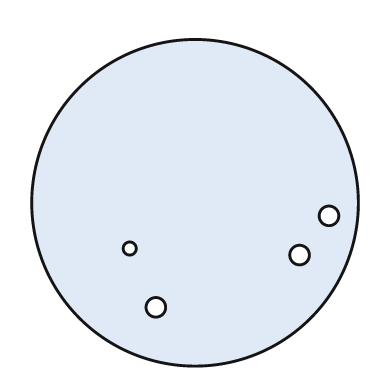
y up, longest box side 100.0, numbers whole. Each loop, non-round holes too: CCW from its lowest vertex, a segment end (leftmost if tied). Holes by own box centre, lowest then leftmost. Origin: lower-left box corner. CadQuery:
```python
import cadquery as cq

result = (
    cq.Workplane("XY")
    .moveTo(50.0, 50.0)
    .circle(50.0)
    .moveTo(38.0, 18.0)
    .circle(3.0)
    .moveTo(82.0, 34.0)
    .circle(3.0)
    .moveTo(30.0, 36.0)
    .circle(2.0)
    .moveTo(91.0, 46.0)
    .circle(3.0)
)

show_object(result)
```